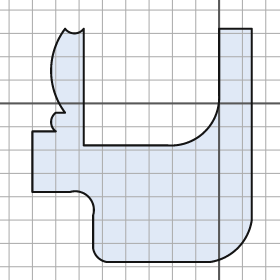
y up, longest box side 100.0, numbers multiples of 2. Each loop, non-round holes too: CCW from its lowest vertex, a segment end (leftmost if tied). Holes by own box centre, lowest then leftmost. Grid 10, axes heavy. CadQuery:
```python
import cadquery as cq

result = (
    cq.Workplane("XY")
    .moveTo(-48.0, -68.0)
    .lineTo(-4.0, -68.0)
    .threePointArc((8.0, -62.0), (14.0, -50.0))
    .lineTo(14.0, 32.0)
    .lineTo(0.0, 32.0)
    .lineTo(0.0, 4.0)
    .threePointArc((-6.0, -12.0), (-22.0, -18.0))
    .lineTo(-58.0, -18.0)
    .lineTo(-58.0, 32.0)
    .threePointArc((-62.0, 30.0), (-66.0, 32.0))
    .threePointArc((-72.0, 14.0), (-66.0, -4.0))
    .lineTo(-70.0, -4.0)
    .threePointArc((-72.0, -8.0), (-70.0, -12.0))
    .lineTo(-80.0, -12.0)
    .lineTo(-80.0, -38.0)
    .lineTo(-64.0, -38.0)
    .threePointArc((-56.0, -40.0), (-54.0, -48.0))
    .lineTo(-54.0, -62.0)
    .threePointArc((-52.0, -66.0), (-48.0, -68.0))
    .close()
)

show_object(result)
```